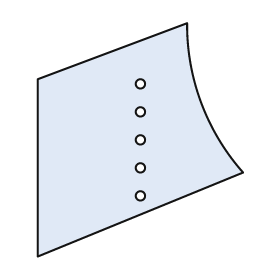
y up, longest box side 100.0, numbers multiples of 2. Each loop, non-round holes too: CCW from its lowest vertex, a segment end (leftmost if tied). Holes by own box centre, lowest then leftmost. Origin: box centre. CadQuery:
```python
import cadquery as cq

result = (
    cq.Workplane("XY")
    .moveTo(-44.0, -50.0)
    .lineTo(44.0, -14.0)
    .threePointArc((26.0, 16.0), (20.0, 50.0))
    .lineTo(-44.0, 26.0)
    .close()
    .moveTo(0.0, -24.0)
    .circle(2.0)
    .moveTo(0.0, -12.0)
    .circle(2.0)
    .moveTo(0.0, 0.0)
    .circle(2.0)
    .moveTo(0.0, 12.0)
    .circle(2.0)
    .moveTo(0.0, 24.0)
    .circle(2.0)
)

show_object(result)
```